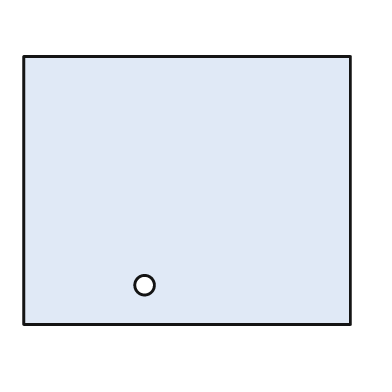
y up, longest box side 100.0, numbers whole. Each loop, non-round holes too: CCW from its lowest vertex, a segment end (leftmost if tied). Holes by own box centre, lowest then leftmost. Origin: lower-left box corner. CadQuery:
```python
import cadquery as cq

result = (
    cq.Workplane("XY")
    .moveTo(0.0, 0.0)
    .lineTo(100.0, 0.0)
    .lineTo(100.0, 82.0)
    .lineTo(0.0, 82.0)
    .close()
    .moveTo(37.0, 12.0)
    .circle(3.0)
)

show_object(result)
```